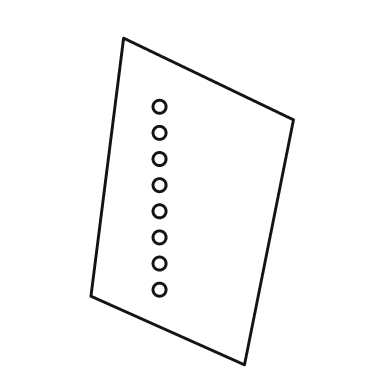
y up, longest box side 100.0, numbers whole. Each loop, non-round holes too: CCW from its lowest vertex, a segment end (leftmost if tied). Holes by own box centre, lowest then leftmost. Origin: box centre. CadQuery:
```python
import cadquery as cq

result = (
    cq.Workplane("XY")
    .moveTo(16.0, -50.0)
    .lineTo(31.0, 25.0)
    .lineTo(-21.0, 50.0)
    .lineTo(-31.0, -29.0)
    .close()
    .moveTo(-10.0, -27.0)
    .circle(2.0)
    .moveTo(-10.0, -19.0)
    .circle(2.0)
    .moveTo(-10.0, -11.0)
    .circle(2.0)
    .moveTo(-10.0, -3.0)
    .circle(2.0)
    .moveTo(-10.0, 5.0)
    .circle(2.0)
    .moveTo(-10.0, 13.0)
    .circle(2.0)
    .moveTo(-10.0, 21.0)
    .circle(2.0)
    .moveTo(-10.0, 29.0)
    .circle(2.0)
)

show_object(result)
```